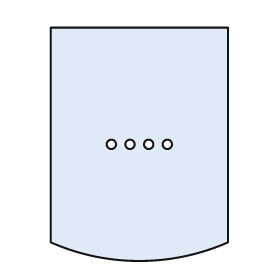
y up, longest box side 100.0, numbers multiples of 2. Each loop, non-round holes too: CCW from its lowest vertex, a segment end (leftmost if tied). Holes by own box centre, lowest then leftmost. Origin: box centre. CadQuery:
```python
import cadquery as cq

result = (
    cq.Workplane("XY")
    .moveTo(-38.0, -42.0)
    .threePointArc((0.0, -50.0), (38.0, -42.0))
    .lineTo(38.0, 50.0)
    .lineTo(-38.0, 50.0)
    .close()
    .moveTo(-12.0, 0.0)
    .circle(2.0)
    .moveTo(-4.0, 0.0)
    .circle(2.0)
    .moveTo(4.0, 0.0)
    .circle(2.0)
    .moveTo(12.0, 0.0)
    .circle(2.0)
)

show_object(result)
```